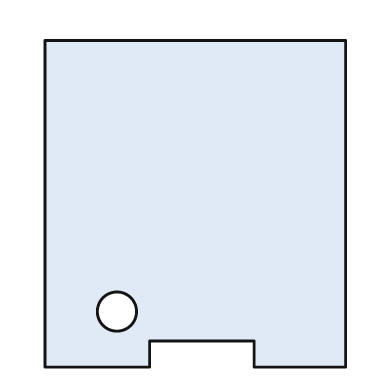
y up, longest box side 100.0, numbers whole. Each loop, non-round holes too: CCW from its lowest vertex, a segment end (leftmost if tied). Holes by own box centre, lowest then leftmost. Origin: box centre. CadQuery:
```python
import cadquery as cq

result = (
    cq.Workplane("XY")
    .moveTo(-46.0, -50.0)
    .lineTo(-14.0, -50.0)
    .lineTo(-14.0, -42.0)
    .lineTo(18.0, -42.0)
    .lineTo(18.0, -50.0)
    .lineTo(46.0, -50.0)
    .lineTo(46.0, 50.0)
    .lineTo(-46.0, 50.0)
    .close()
    .moveTo(-24.0, -33.0)
    .circle(6.0)
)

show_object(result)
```